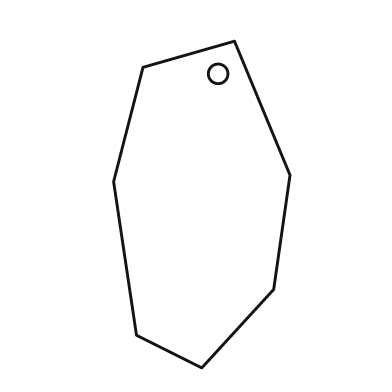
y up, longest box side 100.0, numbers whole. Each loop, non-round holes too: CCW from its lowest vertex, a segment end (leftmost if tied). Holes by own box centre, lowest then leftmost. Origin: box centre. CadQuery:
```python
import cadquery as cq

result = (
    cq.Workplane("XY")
    .moveTo(0.0, -50.0)
    .lineTo(22.0, -26.0)
    .lineTo(27.0, 9.0)
    .lineTo(10.0, 50.0)
    .lineTo(-18.0, 42.0)
    .lineTo(-27.0, 7.0)
    .lineTo(-20.0, -40.0)
    .close()
    .moveTo(5.0, 40.0)
    .circle(3.0)
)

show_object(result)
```